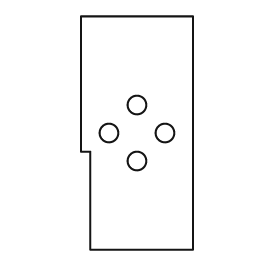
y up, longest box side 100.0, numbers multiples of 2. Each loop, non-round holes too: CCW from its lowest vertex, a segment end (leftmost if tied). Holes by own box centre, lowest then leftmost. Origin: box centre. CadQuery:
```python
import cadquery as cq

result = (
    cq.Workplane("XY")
    .moveTo(-20.0, -50.0)
    .lineTo(24.0, -50.0)
    .lineTo(24.0, 50.0)
    .lineTo(-24.0, 50.0)
    .lineTo(-24.0, -8.0)
    .lineTo(-20.0, -8.0)
    .close()
    .moveTo(0.0, -12.0)
    .circle(4.0)
    .moveTo(-12.0, 0.0)
    .circle(4.0)
    .moveTo(12.0, 0.0)
    .circle(4.0)
    .moveTo(0.0, 12.0)
    .circle(4.0)
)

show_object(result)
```